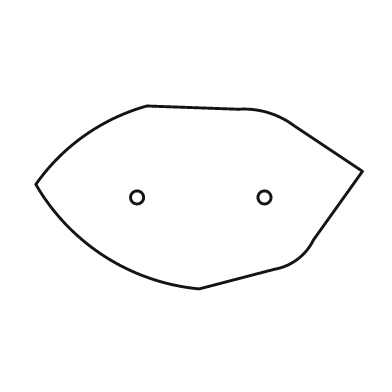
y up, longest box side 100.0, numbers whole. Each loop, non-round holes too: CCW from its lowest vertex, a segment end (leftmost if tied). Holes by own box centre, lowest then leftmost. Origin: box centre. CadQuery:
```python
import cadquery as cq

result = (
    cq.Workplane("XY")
    .moveTo(0.0, -28.0)
    .lineTo(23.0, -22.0)
    .threePointArc((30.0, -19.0), (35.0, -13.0))
    .lineTo(50.0, 8.0)
    .lineTo(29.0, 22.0)
    .threePointArc((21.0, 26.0), (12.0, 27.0))
    .lineTo(-16.0, 28.0)
    .threePointArc((-35.0, 19.0), (-50.0, 4.0))
    .threePointArc((-29.0, -18.0), (0.0, -28.0))
    .close()
    .moveTo(-19.0, 0.0)
    .circle(2.0)
    .moveTo(20.0, 0.0)
    .circle(2.0)
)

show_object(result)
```